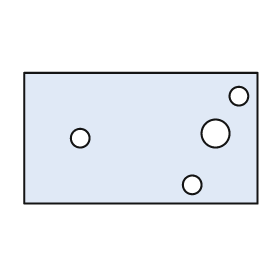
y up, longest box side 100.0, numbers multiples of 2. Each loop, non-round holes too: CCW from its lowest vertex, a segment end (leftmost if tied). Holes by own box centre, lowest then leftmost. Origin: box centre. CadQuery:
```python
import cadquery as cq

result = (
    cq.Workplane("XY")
    .moveTo(-50.0, -28.0)
    .lineTo(50.0, -28.0)
    .lineTo(50.0, 28.0)
    .lineTo(-50.0, 28.0)
    .close()
    .moveTo(22.0, -20.0)
    .circle(4.0)
    .moveTo(-26.0, 0.0)
    .circle(4.0)
    .moveTo(32.0, 2.0)
    .circle(6.0)
    .moveTo(42.0, 18.0)
    .circle(4.0)
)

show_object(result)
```